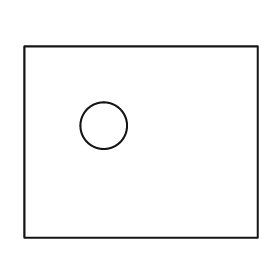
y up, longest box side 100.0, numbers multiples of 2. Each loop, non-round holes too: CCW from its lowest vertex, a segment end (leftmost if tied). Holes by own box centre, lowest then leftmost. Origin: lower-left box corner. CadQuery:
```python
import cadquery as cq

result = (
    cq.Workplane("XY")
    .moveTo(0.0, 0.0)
    .lineTo(100.0, 0.0)
    .lineTo(100.0, 82.0)
    .lineTo(0.0, 82.0)
    .close()
    .moveTo(34.0, 48.0)
    .circle(10.0)
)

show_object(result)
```